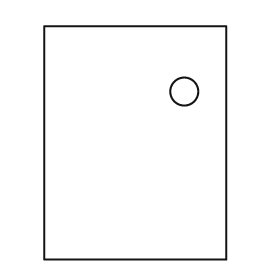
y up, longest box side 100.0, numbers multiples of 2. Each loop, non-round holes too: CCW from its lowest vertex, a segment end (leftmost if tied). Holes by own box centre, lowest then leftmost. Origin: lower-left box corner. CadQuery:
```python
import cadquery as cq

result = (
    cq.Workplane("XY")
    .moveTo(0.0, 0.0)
    .lineTo(78.0, 0.0)
    .lineTo(78.0, 100.0)
    .lineTo(0.0, 100.0)
    .close()
    .moveTo(60.0, 72.0)
    .circle(6.0)
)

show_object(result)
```